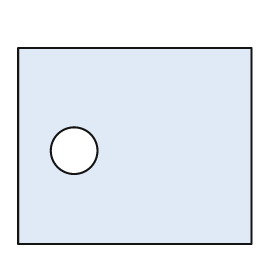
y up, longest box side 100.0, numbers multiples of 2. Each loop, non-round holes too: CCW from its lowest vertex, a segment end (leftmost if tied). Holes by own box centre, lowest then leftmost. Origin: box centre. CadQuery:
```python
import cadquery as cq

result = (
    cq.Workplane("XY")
    .moveTo(-50.0, -42.0)
    .lineTo(50.0, -42.0)
    .lineTo(50.0, 42.0)
    .lineTo(-50.0, 42.0)
    .close()
    .moveTo(-26.0, -2.0)
    .circle(10.0)
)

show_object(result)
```